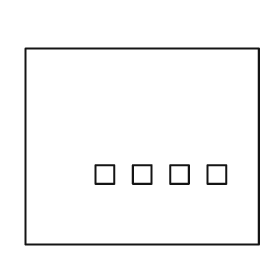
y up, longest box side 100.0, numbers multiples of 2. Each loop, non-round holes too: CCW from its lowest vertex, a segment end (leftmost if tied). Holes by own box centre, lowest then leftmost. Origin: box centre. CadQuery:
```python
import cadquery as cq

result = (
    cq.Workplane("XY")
    .moveTo(-50.0, -42.0)
    .lineTo(50.0, -42.0)
    .lineTo(50.0, 42.0)
    .lineTo(-50.0, 42.0)
    .close()
    .moveTo(-20.0, -16.0)
    .lineTo(-12.0, -16.0)
    .lineTo(-12.0, -8.0)
    .lineTo(-20.0, -8.0)
    .close()
    .moveTo(-4.0, -16.0)
    .lineTo(4.0, -16.0)
    .lineTo(4.0, -8.0)
    .lineTo(-4.0, -8.0)
    .close()
    .moveTo(12.0, -16.0)
    .lineTo(20.0, -16.0)
    .lineTo(20.0, -8.0)
    .lineTo(12.0, -8.0)
    .close()
    .moveTo(28.0, -16.0)
    .lineTo(36.0, -16.0)
    .lineTo(36.0, -8.0)
    .lineTo(28.0, -8.0)
    .close()
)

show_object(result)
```